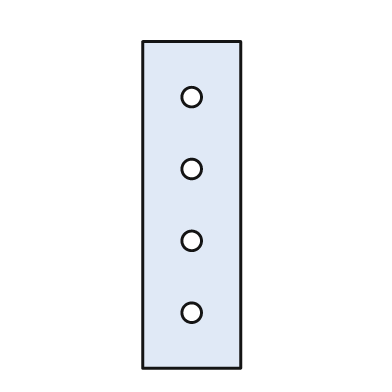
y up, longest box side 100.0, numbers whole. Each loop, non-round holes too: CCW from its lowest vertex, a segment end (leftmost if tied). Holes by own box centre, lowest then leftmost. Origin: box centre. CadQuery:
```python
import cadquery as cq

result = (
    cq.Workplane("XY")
    .moveTo(-15.0, -50.0)
    .lineTo(15.0, -50.0)
    .lineTo(15.0, 50.0)
    .lineTo(-15.0, 50.0)
    .close()
    .moveTo(0.0, -33.0)
    .circle(3.0)
    .moveTo(0.0, -11.0)
    .circle(3.0)
    .moveTo(0.0, 11.0)
    .circle(3.0)
    .moveTo(0.0, 33.0)
    .circle(3.0)
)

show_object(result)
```